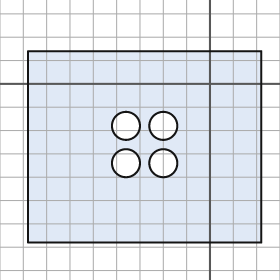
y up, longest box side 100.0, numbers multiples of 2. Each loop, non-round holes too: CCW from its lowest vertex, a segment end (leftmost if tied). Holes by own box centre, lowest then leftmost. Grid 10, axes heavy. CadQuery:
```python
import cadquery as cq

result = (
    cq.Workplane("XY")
    .moveTo(-78.0, -68.0)
    .lineTo(22.0, -68.0)
    .lineTo(22.0, 14.0)
    .lineTo(-78.0, 14.0)
    .close()
    .moveTo(-36.0, -34.0)
    .circle(6.0)
    .moveTo(-20.0, -34.0)
    .circle(6.0)
    .moveTo(-36.0, -18.0)
    .circle(6.0)
    .moveTo(-20.0, -18.0)
    .circle(6.0)
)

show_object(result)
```